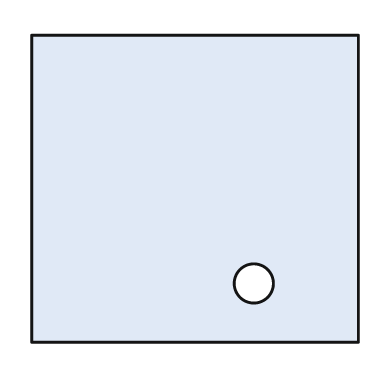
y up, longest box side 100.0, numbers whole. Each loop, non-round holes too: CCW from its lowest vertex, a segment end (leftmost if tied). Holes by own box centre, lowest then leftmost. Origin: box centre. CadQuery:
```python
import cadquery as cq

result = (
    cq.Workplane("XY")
    .moveTo(-50.0, -47.0)
    .lineTo(50.0, -47.0)
    .lineTo(50.0, 47.0)
    .lineTo(-50.0, 47.0)
    .close()
    .moveTo(18.0, -29.0)
    .circle(6.0)
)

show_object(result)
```